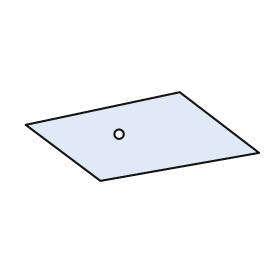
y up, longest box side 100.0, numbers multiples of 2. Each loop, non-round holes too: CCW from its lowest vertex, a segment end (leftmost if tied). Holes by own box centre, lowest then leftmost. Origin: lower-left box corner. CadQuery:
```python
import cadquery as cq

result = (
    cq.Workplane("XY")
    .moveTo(32.0, 0.0)
    .lineTo(100.0, 12.0)
    .lineTo(66.0, 38.0)
    .lineTo(0.0, 24.0)
    .close()
    .moveTo(40.0, 20.0)
    .circle(2.0)
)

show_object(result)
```